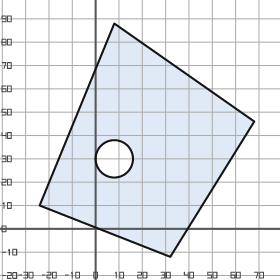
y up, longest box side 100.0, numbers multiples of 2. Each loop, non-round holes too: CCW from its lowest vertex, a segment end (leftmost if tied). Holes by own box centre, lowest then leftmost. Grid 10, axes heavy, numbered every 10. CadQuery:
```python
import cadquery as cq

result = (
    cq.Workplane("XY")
    .moveTo(32.0, -12.0)
    .lineTo(68.0, 46.0)
    .lineTo(8.0, 88.0)
    .lineTo(-24.0, 10.0)
    .close()
    .moveTo(8.0, 30.0)
    .circle(8.0)
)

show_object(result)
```